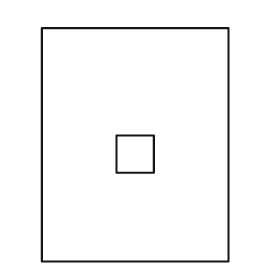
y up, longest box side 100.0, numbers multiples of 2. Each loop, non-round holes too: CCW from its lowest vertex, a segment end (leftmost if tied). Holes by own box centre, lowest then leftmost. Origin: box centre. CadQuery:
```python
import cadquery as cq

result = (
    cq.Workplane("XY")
    .moveTo(-40.0, -50.0)
    .lineTo(40.0, -50.0)
    .lineTo(40.0, 50.0)
    .lineTo(-40.0, 50.0)
    .close()
    .moveTo(-8.0, -12.0)
    .lineTo(8.0, -12.0)
    .lineTo(8.0, 4.0)
    .lineTo(-8.0, 4.0)
    .close()
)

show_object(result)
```